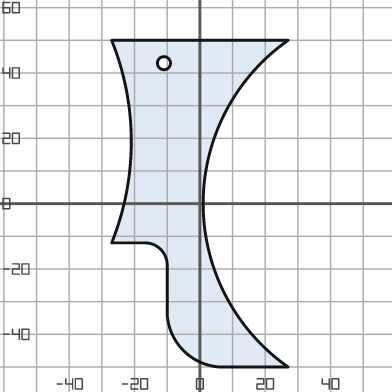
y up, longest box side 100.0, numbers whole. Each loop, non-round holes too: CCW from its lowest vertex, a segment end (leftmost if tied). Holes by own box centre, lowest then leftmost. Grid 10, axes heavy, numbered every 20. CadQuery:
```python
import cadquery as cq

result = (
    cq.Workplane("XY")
    .moveTo(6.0, -50.0)
    .lineTo(27.0, -50.0)
    .threePointArc((1.0, 0.0), (27.0, 50.0))
    .lineTo(-27.0, 50.0)
    .threePointArc((-21.0, 19.0), (-27.0, -12.0))
    .lineTo(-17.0, -12.0)
    .threePointArc((-12.0, -14.0), (-10.0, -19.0))
    .lineTo(-10.0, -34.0)
    .threePointArc((-5.0, -45.0), (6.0, -50.0))
    .close()
    .moveTo(-11.0, 43.0)
    .circle(2.0)
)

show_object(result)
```